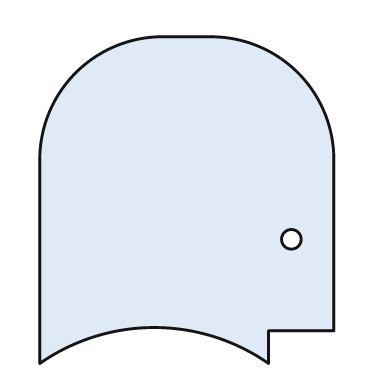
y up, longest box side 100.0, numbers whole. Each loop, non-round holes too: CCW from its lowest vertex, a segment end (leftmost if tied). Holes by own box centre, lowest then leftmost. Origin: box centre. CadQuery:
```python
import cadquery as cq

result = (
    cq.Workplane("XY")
    .moveTo(-45.0, -50.0)
    .threePointArc((-10.0, -39.0), (25.0, -50.0))
    .lineTo(25.0, -40.0)
    .lineTo(45.0, -40.0)
    .lineTo(45.0, 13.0)
    .threePointArc((34.0, 39.0), (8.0, 50.0))
    .lineTo(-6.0, 50.0)
    .threePointArc((-34.0, 39.0), (-45.0, 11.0))
    .close()
    .moveTo(32.0, -12.0)
    .circle(3.0)
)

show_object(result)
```